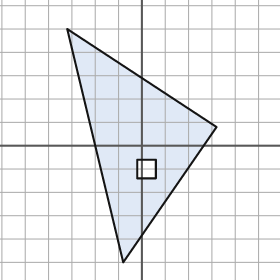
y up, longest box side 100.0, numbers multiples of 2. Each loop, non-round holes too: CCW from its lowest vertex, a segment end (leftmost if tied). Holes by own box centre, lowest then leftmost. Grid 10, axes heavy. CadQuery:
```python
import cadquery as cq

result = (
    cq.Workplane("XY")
    .moveTo(-8.0, -50.0)
    .lineTo(32.0, 8.0)
    .lineTo(-32.0, 50.0)
    .close()
    .moveTo(-2.0, -14.0)
    .lineTo(6.0, -14.0)
    .lineTo(6.0, -6.0)
    .lineTo(-2.0, -6.0)
    .close()
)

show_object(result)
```